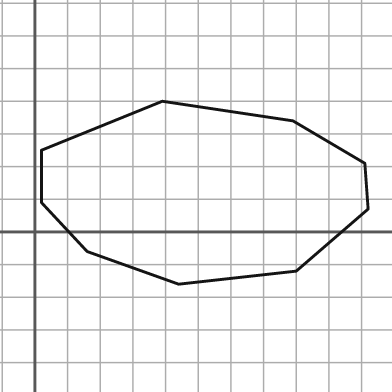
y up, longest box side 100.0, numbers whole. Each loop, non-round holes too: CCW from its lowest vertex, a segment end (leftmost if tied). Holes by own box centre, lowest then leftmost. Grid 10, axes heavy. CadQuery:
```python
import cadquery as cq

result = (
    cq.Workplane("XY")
    .moveTo(44.0, -16.0)
    .lineTo(80.0, -12.0)
    .lineTo(102.0, 7.0)
    .lineTo(101.0, 21.0)
    .lineTo(79.0, 34.0)
    .lineTo(39.0, 40.0)
    .lineTo(2.0, 25.0)
    .lineTo(2.0, 9.0)
    .lineTo(16.0, -6.0)
    .close()
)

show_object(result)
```